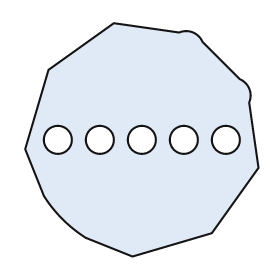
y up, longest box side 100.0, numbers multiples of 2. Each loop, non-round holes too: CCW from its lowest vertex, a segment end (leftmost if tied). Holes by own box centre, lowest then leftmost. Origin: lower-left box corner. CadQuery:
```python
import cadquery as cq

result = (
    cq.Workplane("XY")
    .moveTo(46.0, 0.0)
    .lineTo(80.0, 10.0)
    .lineTo(100.0, 38.0)
    .lineTo(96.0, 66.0)
    .threePointArc((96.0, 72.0), (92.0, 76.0))
    .lineTo(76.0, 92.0)
    .threePointArc((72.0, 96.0), (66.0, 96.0))
    .lineTo(38.0, 100.0)
    .lineTo(10.0, 80.0)
    .lineTo(0.0, 46.0)
    .lineTo(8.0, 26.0)
    .threePointArc((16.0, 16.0), (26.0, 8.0))
    .close()
    .moveTo(14.0, 50.0)
    .circle(6.0)
    .moveTo(32.0, 50.0)
    .circle(6.0)
    .moveTo(50.0, 50.0)
    .circle(6.0)
    .moveTo(68.0, 50.0)
    .circle(6.0)
    .moveTo(86.0, 50.0)
    .circle(6.0)
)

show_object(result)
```